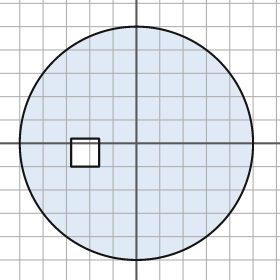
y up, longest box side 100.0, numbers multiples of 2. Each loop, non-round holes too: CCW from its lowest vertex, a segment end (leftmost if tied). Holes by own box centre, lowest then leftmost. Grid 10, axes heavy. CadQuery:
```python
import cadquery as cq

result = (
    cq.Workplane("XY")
    .moveTo(0.0, 0.0)
    .circle(50.0)
    .moveTo(-28.0, -10.0)
    .lineTo(-16.0, -10.0)
    .lineTo(-16.0, 2.0)
    .lineTo(-28.0, 2.0)
    .close()
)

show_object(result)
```